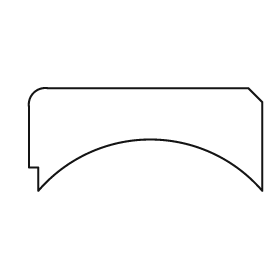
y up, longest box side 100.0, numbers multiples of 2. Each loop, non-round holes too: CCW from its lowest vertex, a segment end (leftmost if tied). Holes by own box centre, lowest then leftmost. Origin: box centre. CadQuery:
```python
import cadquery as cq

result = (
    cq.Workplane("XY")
    .moveTo(-46.0, -22.0)
    .threePointArc((2.0, 0.0), (50.0, -22.0))
    .lineTo(50.0, 16.0)
    .lineTo(44.0, 22.0)
    .lineTo(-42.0, 22.0)
    .threePointArc((-48.0, 20.0), (-50.0, 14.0))
    .lineTo(-50.0, -12.0)
    .lineTo(-46.0, -12.0)
    .close()
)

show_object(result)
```